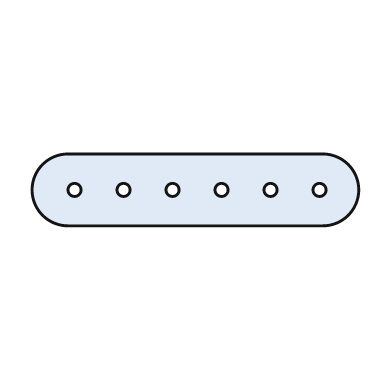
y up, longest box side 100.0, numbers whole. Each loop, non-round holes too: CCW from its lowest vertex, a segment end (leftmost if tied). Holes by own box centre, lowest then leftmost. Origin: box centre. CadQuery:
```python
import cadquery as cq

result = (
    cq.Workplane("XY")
    .moveTo(-39.0, -11.0)
    .lineTo(39.0, -11.0)
    .threePointArc((50.0, 0.0), (39.0, 11.0))
    .lineTo(-39.0, 11.0)
    .threePointArc((-50.0, 0.0), (-39.0, -11.0))
    .close()
    .moveTo(-37.0, 0.0)
    .circle(2.0)
    .moveTo(-22.0, 0.0)
    .circle(2.0)
    .moveTo(-7.0, 0.0)
    .circle(2.0)
    .moveTo(8.0, 0.0)
    .circle(2.0)
    .moveTo(23.0, 0.0)
    .circle(2.0)
    .moveTo(38.0, 0.0)
    .circle(2.0)
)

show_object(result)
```